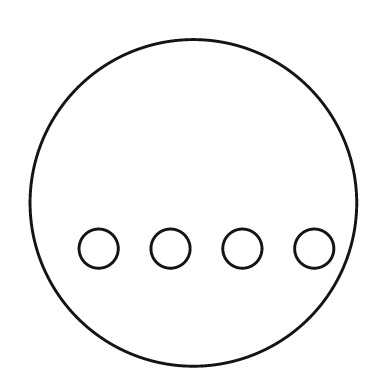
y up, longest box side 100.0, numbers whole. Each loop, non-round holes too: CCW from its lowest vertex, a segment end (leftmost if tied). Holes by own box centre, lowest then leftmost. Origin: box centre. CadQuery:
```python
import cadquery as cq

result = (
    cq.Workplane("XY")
    .moveTo(0.0, 0.0)
    .circle(50.0)
    .moveTo(-29.0, -14.0)
    .circle(6.0)
    .moveTo(-7.0, -14.0)
    .circle(6.0)
    .moveTo(15.0, -14.0)
    .circle(6.0)
    .moveTo(37.0, -14.0)
    .circle(6.0)
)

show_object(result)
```